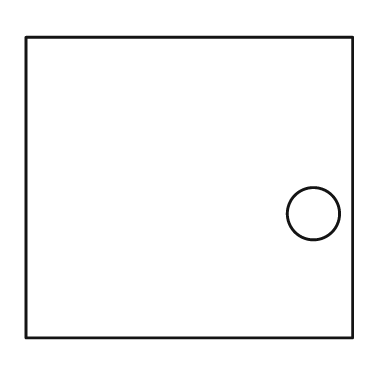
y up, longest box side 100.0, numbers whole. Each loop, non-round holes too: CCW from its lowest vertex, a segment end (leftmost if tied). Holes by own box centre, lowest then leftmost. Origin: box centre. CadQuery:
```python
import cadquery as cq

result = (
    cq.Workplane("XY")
    .moveTo(-50.0, -46.0)
    .lineTo(50.0, -46.0)
    .lineTo(50.0, 46.0)
    .lineTo(-50.0, 46.0)
    .close()
    .moveTo(38.0, -8.0)
    .circle(8.0)
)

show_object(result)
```